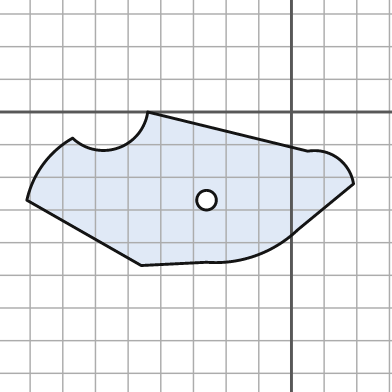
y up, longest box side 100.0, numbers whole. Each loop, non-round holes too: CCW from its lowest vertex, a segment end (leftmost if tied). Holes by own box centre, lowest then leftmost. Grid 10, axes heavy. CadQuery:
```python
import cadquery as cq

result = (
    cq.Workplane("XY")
    .moveTo(-46.0, -47.0)
    .lineTo(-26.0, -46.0)
    .threePointArc((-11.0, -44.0), (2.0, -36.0))
    .lineTo(19.0, -22.0)
    .threePointArc((14.0, -14.0), (5.0, -12.0))
    .lineTo(-44.0, 0.0)
    .threePointArc((-53.0, -11.0), (-67.0, -8.0))
    .threePointArc((-76.0, -16.0), (-81.0, -27.0))
    .close()
    .moveTo(-26.0, -27.0)
    .circle(3.0)
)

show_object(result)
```